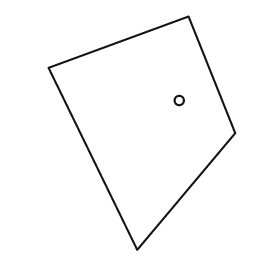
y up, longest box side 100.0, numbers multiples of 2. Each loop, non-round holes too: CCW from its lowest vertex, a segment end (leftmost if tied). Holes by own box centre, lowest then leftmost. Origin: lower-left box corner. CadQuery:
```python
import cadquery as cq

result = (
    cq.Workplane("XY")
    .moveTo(38.0, 0.0)
    .lineTo(80.0, 50.0)
    .lineTo(60.0, 100.0)
    .lineTo(0.0, 78.0)
    .close()
    .moveTo(56.0, 64.0)
    .circle(2.0)
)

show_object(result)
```